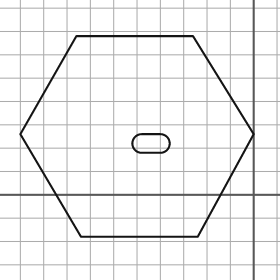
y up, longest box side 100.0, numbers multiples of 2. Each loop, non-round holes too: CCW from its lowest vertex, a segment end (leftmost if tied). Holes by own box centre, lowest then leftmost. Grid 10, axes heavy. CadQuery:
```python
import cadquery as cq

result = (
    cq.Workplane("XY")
    .moveTo(-74.0, -18.0)
    .lineTo(-24.0, -18.0)
    .lineTo(0.0, 26.0)
    .lineTo(-26.0, 68.0)
    .lineTo(-76.0, 68.0)
    .lineTo(-100.0, 26.0)
    .close()
    .moveTo(-48.0, 18.0)
    .lineTo(-40.0, 18.0)
    .threePointArc((-36.0, 22.0), (-40.0, 26.0))
    .lineTo(-48.0, 26.0)
    .threePointArc((-52.0, 22.0), (-48.0, 18.0))
    .close()
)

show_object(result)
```